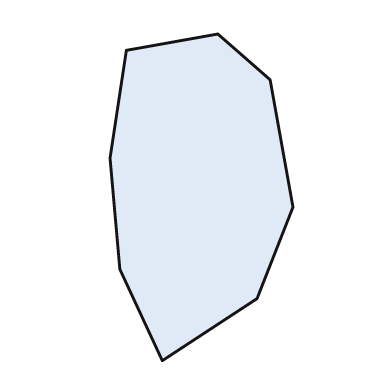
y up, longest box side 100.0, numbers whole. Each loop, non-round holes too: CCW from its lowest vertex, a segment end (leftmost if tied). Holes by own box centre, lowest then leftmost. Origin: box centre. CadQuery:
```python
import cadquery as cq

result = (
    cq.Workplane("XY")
    .moveTo(-12.0, -50.0)
    .lineTo(17.0, -31.0)
    .lineTo(28.0, -3.0)
    .lineTo(21.0, 36.0)
    .lineTo(5.0, 50.0)
    .lineTo(-23.0, 45.0)
    .lineTo(-28.0, 12.0)
    .lineTo(-25.0, -22.0)
    .close()
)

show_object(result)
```